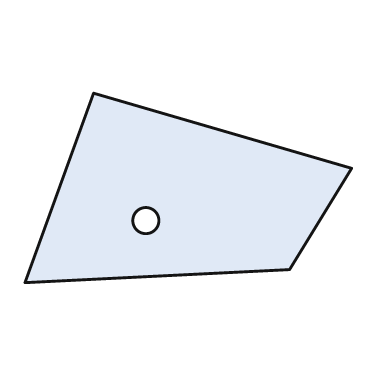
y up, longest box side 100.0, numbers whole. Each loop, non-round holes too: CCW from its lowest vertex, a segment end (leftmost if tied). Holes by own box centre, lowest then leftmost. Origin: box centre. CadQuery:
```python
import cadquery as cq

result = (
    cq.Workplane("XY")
    .moveTo(-50.0, -29.0)
    .lineTo(31.0, -25.0)
    .lineTo(50.0, 6.0)
    .lineTo(-29.0, 29.0)
    .close()
    .moveTo(-13.0, -10.0)
    .circle(4.0)
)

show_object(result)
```